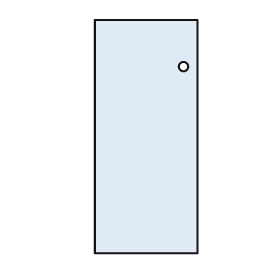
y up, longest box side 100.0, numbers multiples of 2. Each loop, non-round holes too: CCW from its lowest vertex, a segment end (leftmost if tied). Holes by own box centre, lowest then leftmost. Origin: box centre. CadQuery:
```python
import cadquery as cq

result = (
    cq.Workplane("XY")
    .moveTo(-22.0, -50.0)
    .lineTo(22.0, -50.0)
    .lineTo(22.0, 50.0)
    .lineTo(-22.0, 50.0)
    .close()
    .moveTo(16.0, 30.0)
    .circle(2.0)
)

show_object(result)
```